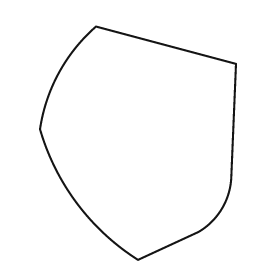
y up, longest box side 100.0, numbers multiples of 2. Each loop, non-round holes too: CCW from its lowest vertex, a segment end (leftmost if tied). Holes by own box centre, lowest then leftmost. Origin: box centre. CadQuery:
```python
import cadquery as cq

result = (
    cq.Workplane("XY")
    .moveTo(0.0, -50.0)
    .lineTo(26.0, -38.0)
    .threePointArc((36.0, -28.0), (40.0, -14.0))
    .lineTo(42.0, 34.0)
    .lineTo(-18.0, 50.0)
    .threePointArc((-34.0, 30.0), (-42.0, 6.0))
    .threePointArc((-26.0, -26.0), (0.0, -50.0))
    .close()
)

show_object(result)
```